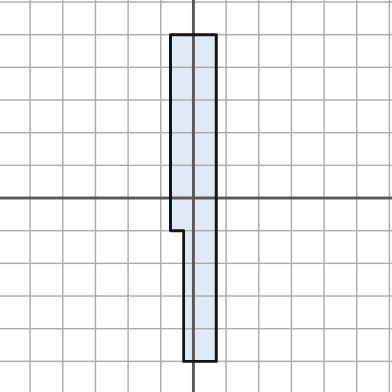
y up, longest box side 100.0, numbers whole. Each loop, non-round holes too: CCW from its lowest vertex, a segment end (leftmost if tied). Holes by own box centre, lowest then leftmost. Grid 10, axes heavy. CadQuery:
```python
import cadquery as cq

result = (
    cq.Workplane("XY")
    .moveTo(-3.0, -50.0)
    .lineTo(7.0, -50.0)
    .lineTo(7.0, 50.0)
    .lineTo(-7.0, 50.0)
    .lineTo(-7.0, -10.0)
    .lineTo(-3.0, -10.0)
    .close()
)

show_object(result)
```